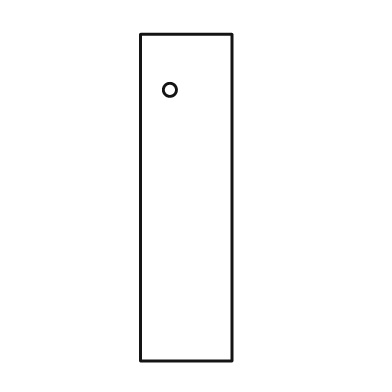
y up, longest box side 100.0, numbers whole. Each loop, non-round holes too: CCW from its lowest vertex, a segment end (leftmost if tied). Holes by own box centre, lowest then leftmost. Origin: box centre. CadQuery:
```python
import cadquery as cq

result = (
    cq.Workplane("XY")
    .moveTo(-14.0, -50.0)
    .lineTo(14.0, -50.0)
    .lineTo(14.0, 50.0)
    .lineTo(-14.0, 50.0)
    .close()
    .moveTo(-5.0, 33.0)
    .circle(2.0)
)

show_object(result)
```